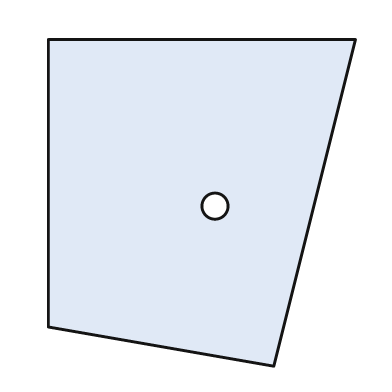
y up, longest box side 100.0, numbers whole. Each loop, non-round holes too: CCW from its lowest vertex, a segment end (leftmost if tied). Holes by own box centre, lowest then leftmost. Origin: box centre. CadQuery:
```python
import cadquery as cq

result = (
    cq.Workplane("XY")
    .moveTo(22.0, -50.0)
    .lineTo(47.0, 50.0)
    .lineTo(-47.0, 50.0)
    .lineTo(-47.0, -38.0)
    .close()
    .moveTo(4.0, -1.0)
    .circle(4.0)
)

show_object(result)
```